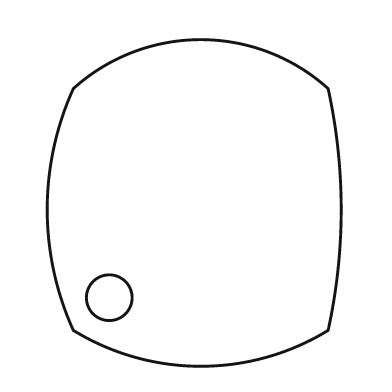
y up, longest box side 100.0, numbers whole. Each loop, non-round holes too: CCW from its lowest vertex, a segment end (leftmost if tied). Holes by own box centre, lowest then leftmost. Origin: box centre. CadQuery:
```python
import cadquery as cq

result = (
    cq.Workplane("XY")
    .moveTo(-37.0, -39.0)
    .threePointArc((2.0, -50.0), (41.0, -39.0))
    .threePointArc((45.0, -2.0), (41.0, 35.0))
    .threePointArc((2.0, 50.0), (-37.0, 35.0))
    .threePointArc((-45.0, -2.0), (-37.0, -39.0))
    .close()
    .moveTo(-26.0, -29.0)
    .circle(7.0)
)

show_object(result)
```